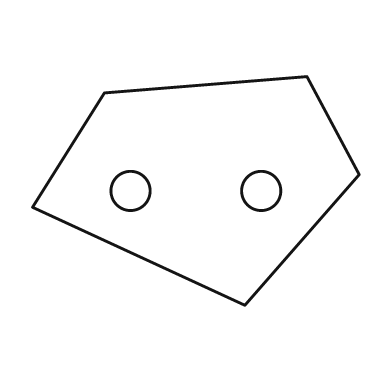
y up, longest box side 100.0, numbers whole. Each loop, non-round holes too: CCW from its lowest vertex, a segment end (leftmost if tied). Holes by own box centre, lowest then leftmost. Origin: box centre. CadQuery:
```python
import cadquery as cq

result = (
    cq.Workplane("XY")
    .moveTo(15.0, -35.0)
    .lineTo(50.0, 5.0)
    .lineTo(34.0, 35.0)
    .lineTo(-28.0, 30.0)
    .lineTo(-50.0, -5.0)
    .close()
    .moveTo(-20.0, 0.0)
    .circle(6.0)
    .moveTo(20.0, 0.0)
    .circle(6.0)
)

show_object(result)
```